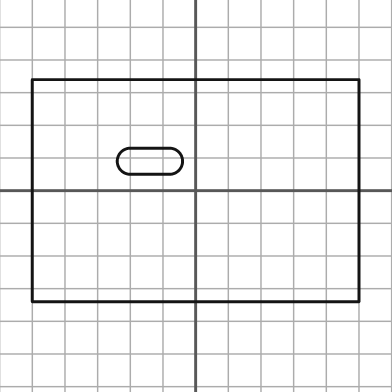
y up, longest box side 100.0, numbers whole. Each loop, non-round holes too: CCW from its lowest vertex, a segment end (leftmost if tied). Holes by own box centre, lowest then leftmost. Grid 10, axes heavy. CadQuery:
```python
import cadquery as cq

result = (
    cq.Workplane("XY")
    .moveTo(-50.0, -34.0)
    .lineTo(50.0, -34.0)
    .lineTo(50.0, 34.0)
    .lineTo(-50.0, 34.0)
    .close()
    .moveTo(-20.0, 5.0)
    .lineTo(-8.0, 5.0)
    .threePointArc((-4.0, 9.0), (-8.0, 13.0))
    .lineTo(-20.0, 13.0)
    .threePointArc((-24.0, 9.0), (-20.0, 5.0))
    .close()
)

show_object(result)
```